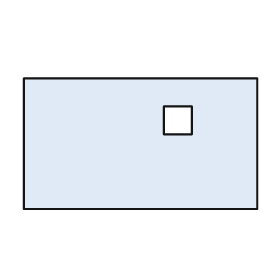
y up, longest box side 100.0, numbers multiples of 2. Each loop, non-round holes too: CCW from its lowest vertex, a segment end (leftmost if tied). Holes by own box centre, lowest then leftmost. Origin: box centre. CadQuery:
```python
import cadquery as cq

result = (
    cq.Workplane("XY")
    .moveTo(-50.0, -28.0)
    .lineTo(50.0, -28.0)
    .lineTo(50.0, 28.0)
    .lineTo(-50.0, 28.0)
    .close()
    .moveTo(10.0, 4.0)
    .lineTo(22.0, 4.0)
    .lineTo(22.0, 16.0)
    .lineTo(10.0, 16.0)
    .close()
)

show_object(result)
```